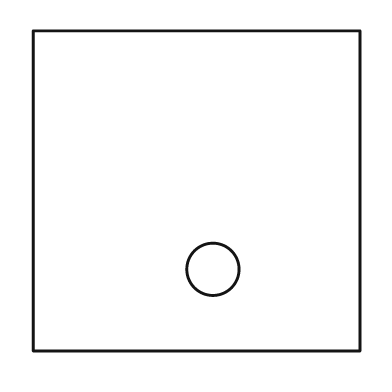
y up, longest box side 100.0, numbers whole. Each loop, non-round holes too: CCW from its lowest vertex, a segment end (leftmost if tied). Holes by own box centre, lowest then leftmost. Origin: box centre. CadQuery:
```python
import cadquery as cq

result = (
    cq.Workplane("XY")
    .moveTo(-50.0, -49.0)
    .lineTo(50.0, -49.0)
    .lineTo(50.0, 49.0)
    .lineTo(-50.0, 49.0)
    .close()
    .moveTo(5.0, -24.0)
    .circle(8.0)
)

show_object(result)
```